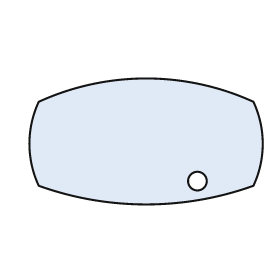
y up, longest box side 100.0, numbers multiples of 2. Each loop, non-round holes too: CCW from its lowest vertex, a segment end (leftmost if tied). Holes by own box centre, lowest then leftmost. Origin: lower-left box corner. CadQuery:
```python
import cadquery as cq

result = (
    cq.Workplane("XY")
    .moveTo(4.0, 8.0)
    .threePointArc((50.0, 0.0), (96.0, 8.0))
    .threePointArc((100.0, 26.0), (96.0, 44.0))
    .threePointArc((50.0, 54.0), (4.0, 44.0))
    .threePointArc((0.0, 26.0), (4.0, 8.0))
    .close()
    .moveTo(72.0, 10.0)
    .circle(4.0)
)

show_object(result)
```